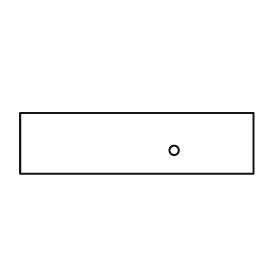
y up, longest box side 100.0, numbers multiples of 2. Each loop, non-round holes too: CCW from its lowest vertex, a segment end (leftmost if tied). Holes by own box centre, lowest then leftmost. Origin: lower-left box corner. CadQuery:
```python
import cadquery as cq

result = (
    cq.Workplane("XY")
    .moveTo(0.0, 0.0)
    .lineTo(100.0, 0.0)
    .lineTo(100.0, 26.0)
    .lineTo(0.0, 26.0)
    .close()
    .moveTo(66.0, 10.0)
    .circle(2.0)
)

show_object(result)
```